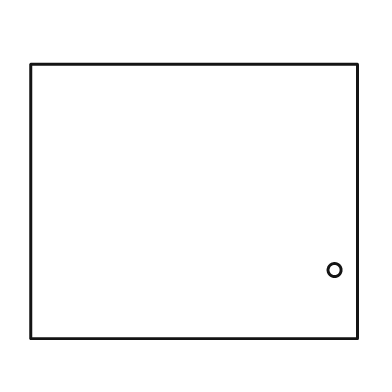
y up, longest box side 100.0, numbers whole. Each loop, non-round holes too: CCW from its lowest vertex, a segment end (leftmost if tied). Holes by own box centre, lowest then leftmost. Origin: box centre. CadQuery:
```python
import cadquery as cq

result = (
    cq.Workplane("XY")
    .moveTo(-50.0, -42.0)
    .lineTo(50.0, -42.0)
    .lineTo(50.0, 42.0)
    .lineTo(-50.0, 42.0)
    .close()
    .moveTo(43.0, -21.0)
    .circle(2.0)
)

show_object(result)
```